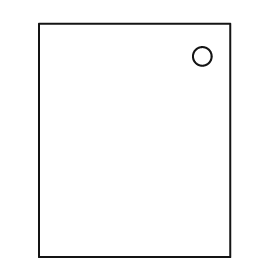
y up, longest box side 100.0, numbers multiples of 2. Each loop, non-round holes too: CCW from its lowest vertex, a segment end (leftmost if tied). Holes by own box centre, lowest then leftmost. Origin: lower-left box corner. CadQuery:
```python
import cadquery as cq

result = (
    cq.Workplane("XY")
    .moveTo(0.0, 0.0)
    .lineTo(82.0, 0.0)
    .lineTo(82.0, 100.0)
    .lineTo(0.0, 100.0)
    .close()
    .moveTo(70.0, 86.0)
    .circle(4.0)
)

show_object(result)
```